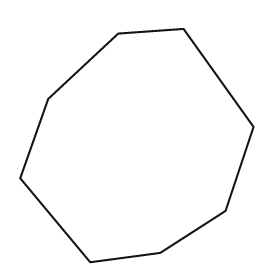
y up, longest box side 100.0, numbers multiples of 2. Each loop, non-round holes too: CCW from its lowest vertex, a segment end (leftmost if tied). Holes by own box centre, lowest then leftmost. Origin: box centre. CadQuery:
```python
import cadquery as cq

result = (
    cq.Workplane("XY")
    .moveTo(-20.0, -50.0)
    .lineTo(10.0, -46.0)
    .lineTo(38.0, -28.0)
    .lineTo(50.0, 8.0)
    .lineTo(20.0, 50.0)
    .lineTo(-8.0, 48.0)
    .lineTo(-38.0, 20.0)
    .lineTo(-50.0, -14.0)
    .close()
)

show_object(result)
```